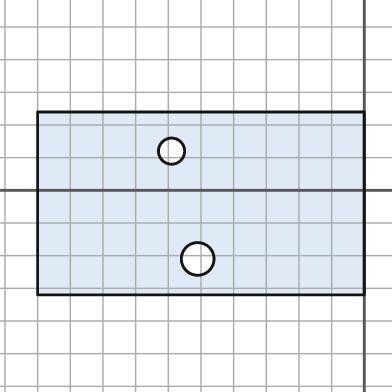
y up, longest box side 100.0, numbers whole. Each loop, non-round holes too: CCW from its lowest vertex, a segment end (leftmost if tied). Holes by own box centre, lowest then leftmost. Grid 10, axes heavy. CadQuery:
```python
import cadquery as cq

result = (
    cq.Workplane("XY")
    .moveTo(-100.0, -32.0)
    .lineTo(0.0, -32.0)
    .lineTo(0.0, 24.0)
    .lineTo(-100.0, 24.0)
    .close()
    .moveTo(-51.0, -21.0)
    .circle(5.0)
    .moveTo(-59.0, 12.0)
    .circle(4.0)
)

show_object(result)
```